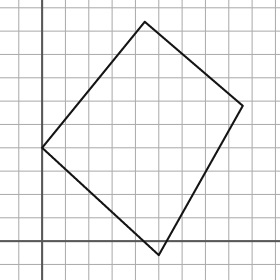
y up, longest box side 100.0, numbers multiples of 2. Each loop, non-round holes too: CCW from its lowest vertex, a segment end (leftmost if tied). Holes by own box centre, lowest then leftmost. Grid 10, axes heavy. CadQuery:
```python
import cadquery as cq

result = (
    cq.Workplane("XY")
    .moveTo(50.0, -6.0)
    .lineTo(86.0, 58.0)
    .lineTo(44.0, 94.0)
    .lineTo(0.0, 40.0)
    .close()
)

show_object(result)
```